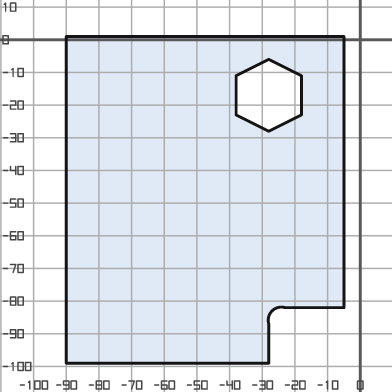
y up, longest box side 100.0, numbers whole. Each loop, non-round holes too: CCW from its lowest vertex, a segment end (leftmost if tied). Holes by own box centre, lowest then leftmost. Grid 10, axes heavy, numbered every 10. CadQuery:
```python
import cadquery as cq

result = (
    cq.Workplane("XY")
    .moveTo(-90.0, -99.0)
    .lineTo(-28.0, -99.0)
    .lineTo(-28.0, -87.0)
    .threePointArc((-27.0, -83.0), (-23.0, -82.0))
    .lineTo(-5.0, -82.0)
    .lineTo(-5.0, 1.0)
    .lineTo(-90.0, 1.0)
    .close()
    .moveTo(-28.0, -28.0)
    .lineTo(-18.0, -23.0)
    .lineTo(-18.0, -11.0)
    .lineTo(-28.0, -6.0)
    .lineTo(-38.0, -11.0)
    .lineTo(-38.0, -23.0)
    .close()
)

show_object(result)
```